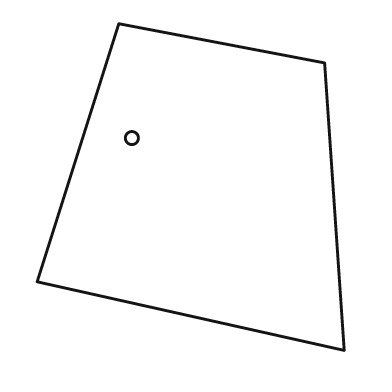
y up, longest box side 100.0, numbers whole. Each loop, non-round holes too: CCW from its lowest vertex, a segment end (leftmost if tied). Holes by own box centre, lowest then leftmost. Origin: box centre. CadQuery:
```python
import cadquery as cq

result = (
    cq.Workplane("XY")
    .moveTo(47.0, -50.0)
    .lineTo(41.0, 38.0)
    .lineTo(-22.0, 50.0)
    .lineTo(-47.0, -29.0)
    .close()
    .moveTo(-18.0, 15.0)
    .circle(2.0)
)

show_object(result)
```